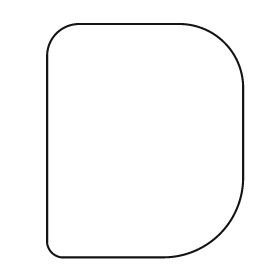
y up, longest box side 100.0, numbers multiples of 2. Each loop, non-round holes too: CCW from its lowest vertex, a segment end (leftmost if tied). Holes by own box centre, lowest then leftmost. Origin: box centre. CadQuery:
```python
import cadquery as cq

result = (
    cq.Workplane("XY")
    .moveTo(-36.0, -50.0)
    .lineTo(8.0, -50.0)
    .threePointArc((32.0, -40.0), (42.0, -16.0))
    .lineTo(42.0, 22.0)
    .threePointArc((34.0, 42.0), (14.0, 50.0))
    .lineTo(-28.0, 50.0)
    .threePointArc((-38.0, 46.0), (-42.0, 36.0))
    .lineTo(-42.0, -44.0)
    .threePointArc((-40.0, -48.0), (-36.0, -50.0))
    .close()
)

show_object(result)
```